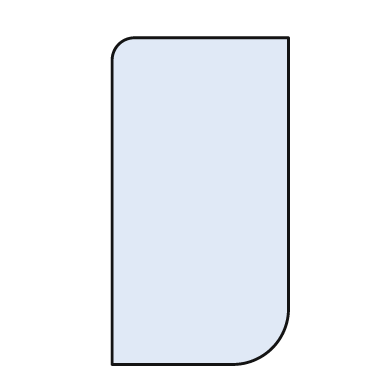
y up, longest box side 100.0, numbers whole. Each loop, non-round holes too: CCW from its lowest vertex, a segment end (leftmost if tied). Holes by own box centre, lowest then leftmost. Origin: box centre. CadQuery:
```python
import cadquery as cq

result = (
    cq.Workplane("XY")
    .moveTo(-27.0, -50.0)
    .lineTo(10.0, -50.0)
    .threePointArc((22.0, -45.0), (27.0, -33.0))
    .lineTo(27.0, 50.0)
    .lineTo(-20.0, 50.0)
    .threePointArc((-25.0, 48.0), (-27.0, 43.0))
    .close()
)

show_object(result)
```